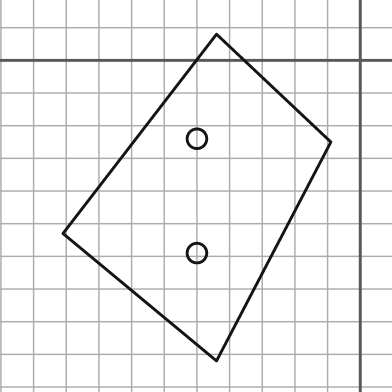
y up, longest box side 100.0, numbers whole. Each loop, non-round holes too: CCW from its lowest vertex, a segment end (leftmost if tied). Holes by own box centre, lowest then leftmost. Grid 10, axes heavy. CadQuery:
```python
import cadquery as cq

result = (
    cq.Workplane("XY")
    .moveTo(-44.0, -92.0)
    .lineTo(-9.0, -25.0)
    .lineTo(-44.0, 8.0)
    .lineTo(-91.0, -53.0)
    .close()
    .moveTo(-50.0, -59.0)
    .circle(3.0)
    .moveTo(-50.0, -24.0)
    .circle(3.0)
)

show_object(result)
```